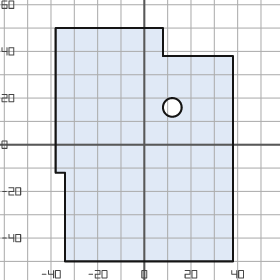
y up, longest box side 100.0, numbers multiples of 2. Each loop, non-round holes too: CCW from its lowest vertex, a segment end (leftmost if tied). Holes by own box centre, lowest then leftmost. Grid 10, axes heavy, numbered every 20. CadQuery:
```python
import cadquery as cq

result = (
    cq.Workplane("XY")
    .moveTo(-34.0, -50.0)
    .lineTo(38.0, -50.0)
    .lineTo(38.0, 38.0)
    .lineTo(8.0, 38.0)
    .lineTo(8.0, 50.0)
    .lineTo(-38.0, 50.0)
    .lineTo(-38.0, -12.0)
    .lineTo(-34.0, -12.0)
    .close()
    .moveTo(12.0, 16.0)
    .circle(4.0)
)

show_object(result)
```